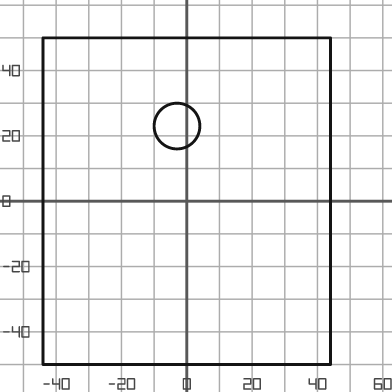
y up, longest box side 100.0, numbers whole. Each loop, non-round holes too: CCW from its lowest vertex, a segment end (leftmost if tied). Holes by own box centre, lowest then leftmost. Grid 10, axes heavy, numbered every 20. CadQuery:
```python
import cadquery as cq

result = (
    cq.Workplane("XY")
    .moveTo(-44.0, -50.0)
    .lineTo(44.0, -50.0)
    .lineTo(44.0, 50.0)
    .lineTo(-44.0, 50.0)
    .close()
    .moveTo(-3.0, 23.0)
    .circle(7.0)
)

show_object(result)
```